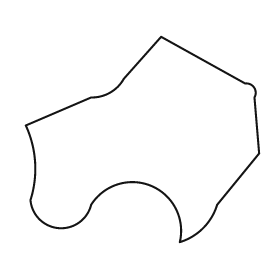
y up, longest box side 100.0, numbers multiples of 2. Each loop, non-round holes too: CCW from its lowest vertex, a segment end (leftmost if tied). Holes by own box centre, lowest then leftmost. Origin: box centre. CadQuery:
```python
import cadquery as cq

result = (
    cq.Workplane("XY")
    .moveTo(16.0, -44.0)
    .threePointArc((26.0, -38.0), (32.0, -28.0))
    .lineTo(50.0, -6.0)
    .lineTo(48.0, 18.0)
    .threePointArc((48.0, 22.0), (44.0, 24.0))
    .lineTo(8.0, 44.0)
    .lineTo(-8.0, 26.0)
    .threePointArc((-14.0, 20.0), (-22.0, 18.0))
    .lineTo(-50.0, 6.0)
    .threePointArc((-46.0, -10.0), (-48.0, -26.0))
    .threePointArc((-36.0, -38.0), (-22.0, -28.0))
    .threePointArc((4.0, -20.0), (16.0, -44.0))
    .close()
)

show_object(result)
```